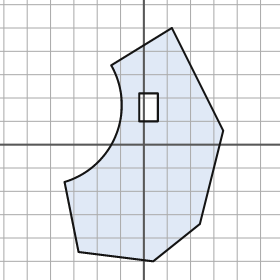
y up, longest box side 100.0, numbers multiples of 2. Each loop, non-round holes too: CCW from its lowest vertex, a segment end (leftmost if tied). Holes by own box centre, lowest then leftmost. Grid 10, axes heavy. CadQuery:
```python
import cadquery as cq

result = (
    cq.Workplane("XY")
    .moveTo(4.0, -50.0)
    .lineTo(24.0, -34.0)
    .lineTo(34.0, 6.0)
    .lineTo(12.0, 50.0)
    .lineTo(-14.0, 34.0)
    .threePointArc((-12.0, 4.0), (-34.0, -16.0))
    .lineTo(-28.0, -46.0)
    .close()
    .moveTo(-2.0, 10.0)
    .lineTo(6.0, 10.0)
    .lineTo(6.0, 22.0)
    .lineTo(-2.0, 22.0)
    .close()
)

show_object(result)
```